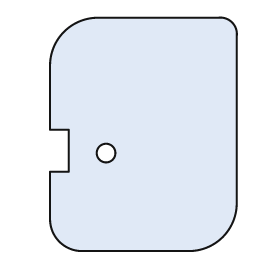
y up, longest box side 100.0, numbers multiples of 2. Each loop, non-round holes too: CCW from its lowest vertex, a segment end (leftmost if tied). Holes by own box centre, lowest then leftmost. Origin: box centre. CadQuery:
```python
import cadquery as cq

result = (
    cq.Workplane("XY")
    .moveTo(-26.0, -50.0)
    .lineTo(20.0, -50.0)
    .threePointArc((34.0, -44.0), (40.0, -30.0))
    .lineTo(40.0, 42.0)
    .threePointArc((38.0, 48.0), (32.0, 50.0))
    .lineTo(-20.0, 50.0)
    .threePointArc((-34.0, 44.0), (-40.0, 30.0))
    .lineTo(-40.0, 2.0)
    .lineTo(-32.0, 2.0)
    .lineTo(-32.0, -16.0)
    .lineTo(-40.0, -16.0)
    .lineTo(-40.0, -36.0)
    .threePointArc((-36.0, -46.0), (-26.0, -50.0))
    .close()
    .moveTo(-16.0, -8.0)
    .circle(4.0)
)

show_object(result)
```